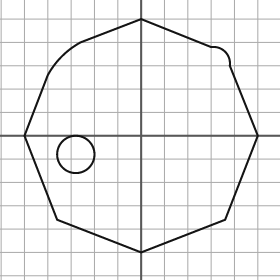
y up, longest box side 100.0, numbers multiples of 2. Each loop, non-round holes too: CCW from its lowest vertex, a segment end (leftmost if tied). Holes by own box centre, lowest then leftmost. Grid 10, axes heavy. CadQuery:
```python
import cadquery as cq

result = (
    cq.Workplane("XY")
    .moveTo(0.0, -50.0)
    .lineTo(36.0, -36.0)
    .lineTo(50.0, 0.0)
    .lineTo(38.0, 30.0)
    .threePointArc((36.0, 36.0), (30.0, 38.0))
    .lineTo(0.0, 50.0)
    .lineTo(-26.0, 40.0)
    .threePointArc((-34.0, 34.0), (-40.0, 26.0))
    .lineTo(-50.0, 0.0)
    .lineTo(-36.0, -36.0)
    .close()
    .moveTo(-28.0, -8.0)
    .circle(8.0)
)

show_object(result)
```